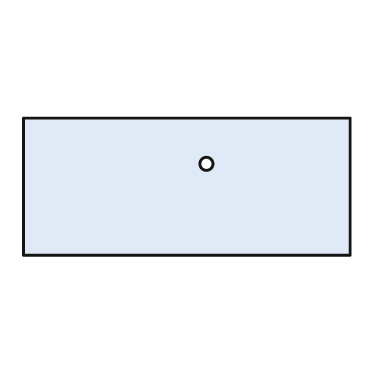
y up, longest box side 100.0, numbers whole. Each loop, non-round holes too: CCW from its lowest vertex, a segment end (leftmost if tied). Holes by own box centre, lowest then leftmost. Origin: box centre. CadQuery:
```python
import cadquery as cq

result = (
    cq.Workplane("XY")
    .moveTo(-50.0, -21.0)
    .lineTo(50.0, -21.0)
    .lineTo(50.0, 21.0)
    .lineTo(-50.0, 21.0)
    .close()
    .moveTo(6.0, 7.0)
    .circle(2.0)
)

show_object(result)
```